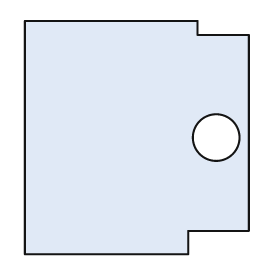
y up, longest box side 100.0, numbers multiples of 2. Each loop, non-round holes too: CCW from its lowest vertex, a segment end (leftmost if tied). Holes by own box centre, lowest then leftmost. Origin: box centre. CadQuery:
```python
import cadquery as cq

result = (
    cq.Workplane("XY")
    .moveTo(-48.0, -50.0)
    .lineTo(22.0, -50.0)
    .lineTo(22.0, -40.0)
    .lineTo(48.0, -40.0)
    .lineTo(48.0, 44.0)
    .lineTo(26.0, 44.0)
    .lineTo(26.0, 50.0)
    .lineTo(-48.0, 50.0)
    .close()
    .moveTo(34.0, 0.0)
    .circle(10.0)
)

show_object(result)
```